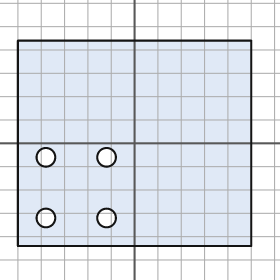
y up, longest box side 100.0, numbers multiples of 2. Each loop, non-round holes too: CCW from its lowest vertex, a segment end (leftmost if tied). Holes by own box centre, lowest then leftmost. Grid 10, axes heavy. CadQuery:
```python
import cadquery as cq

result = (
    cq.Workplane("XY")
    .moveTo(-50.0, -44.0)
    .lineTo(50.0, -44.0)
    .lineTo(50.0, 44.0)
    .lineTo(-50.0, 44.0)
    .close()
    .moveTo(-38.0, -32.0)
    .circle(4.0)
    .moveTo(-12.0, -32.0)
    .circle(4.0)
    .moveTo(-38.0, -6.0)
    .circle(4.0)
    .moveTo(-12.0, -6.0)
    .circle(4.0)
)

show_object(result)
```